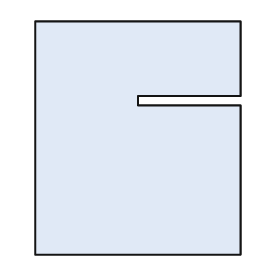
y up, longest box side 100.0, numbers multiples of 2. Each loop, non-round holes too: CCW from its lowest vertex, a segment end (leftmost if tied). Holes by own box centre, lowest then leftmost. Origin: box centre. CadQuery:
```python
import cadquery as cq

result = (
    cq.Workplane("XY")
    .moveTo(-44.0, -50.0)
    .lineTo(44.0, -50.0)
    .lineTo(44.0, 14.0)
    .lineTo(0.0, 14.0)
    .lineTo(0.0, 18.0)
    .lineTo(44.0, 18.0)
    .lineTo(44.0, 50.0)
    .lineTo(-44.0, 50.0)
    .close()
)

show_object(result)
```